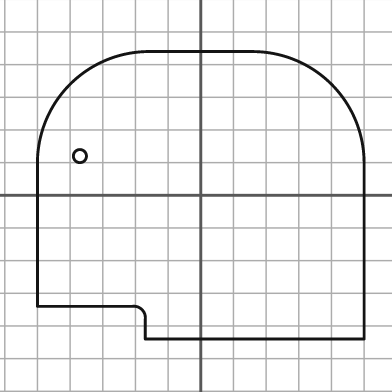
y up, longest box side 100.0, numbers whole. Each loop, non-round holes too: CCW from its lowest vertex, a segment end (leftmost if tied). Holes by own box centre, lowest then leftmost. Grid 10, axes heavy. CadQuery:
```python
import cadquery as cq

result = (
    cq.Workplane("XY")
    .moveTo(-17.0, -44.0)
    .lineTo(50.0, -44.0)
    .lineTo(50.0, 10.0)
    .threePointArc((40.0, 34.0), (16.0, 44.0))
    .lineTo(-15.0, 44.0)
    .threePointArc((-40.0, 34.0), (-50.0, 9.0))
    .lineTo(-50.0, -34.0)
    .lineTo(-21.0, -34.0)
    .threePointArc((-18.0, -35.0), (-17.0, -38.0))
    .close()
    .moveTo(-37.0, 12.0)
    .circle(2.0)
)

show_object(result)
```